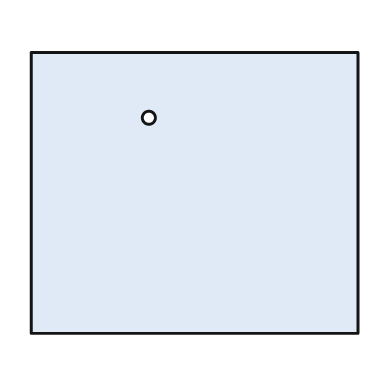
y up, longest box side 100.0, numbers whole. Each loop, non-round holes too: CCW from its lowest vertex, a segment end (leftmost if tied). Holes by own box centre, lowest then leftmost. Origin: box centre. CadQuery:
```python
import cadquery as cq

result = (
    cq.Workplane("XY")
    .moveTo(-50.0, -43.0)
    .lineTo(50.0, -43.0)
    .lineTo(50.0, 43.0)
    .lineTo(-50.0, 43.0)
    .close()
    .moveTo(-14.0, 23.0)
    .circle(2.0)
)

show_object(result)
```